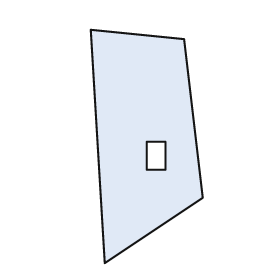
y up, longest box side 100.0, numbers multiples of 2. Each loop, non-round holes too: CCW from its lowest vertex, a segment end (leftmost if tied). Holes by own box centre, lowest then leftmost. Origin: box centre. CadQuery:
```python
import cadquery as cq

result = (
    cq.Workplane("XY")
    .moveTo(-18.0, -50.0)
    .lineTo(24.0, -22.0)
    .lineTo(16.0, 46.0)
    .lineTo(-24.0, 50.0)
    .close()
    .moveTo(0.0, -10.0)
    .lineTo(8.0, -10.0)
    .lineTo(8.0, 2.0)
    .lineTo(0.0, 2.0)
    .close()
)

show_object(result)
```